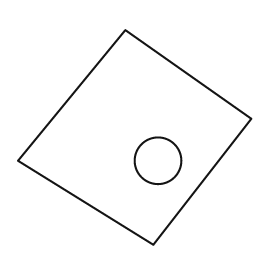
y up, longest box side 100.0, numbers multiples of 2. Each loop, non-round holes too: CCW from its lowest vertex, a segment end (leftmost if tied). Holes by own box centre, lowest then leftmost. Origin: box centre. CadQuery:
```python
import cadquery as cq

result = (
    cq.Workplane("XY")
    .moveTo(8.0, -46.0)
    .lineTo(50.0, 8.0)
    .lineTo(-4.0, 46.0)
    .lineTo(-50.0, -10.0)
    .close()
    .moveTo(10.0, -10.0)
    .circle(10.0)
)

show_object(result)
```